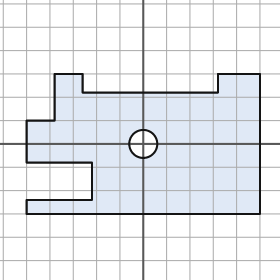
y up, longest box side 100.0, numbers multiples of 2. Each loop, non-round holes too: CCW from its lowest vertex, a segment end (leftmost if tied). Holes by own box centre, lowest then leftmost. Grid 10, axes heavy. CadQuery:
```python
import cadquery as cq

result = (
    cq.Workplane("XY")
    .moveTo(-50.0, -30.0)
    .lineTo(50.0, -30.0)
    .lineTo(50.0, 30.0)
    .lineTo(32.0, 30.0)
    .lineTo(32.0, 22.0)
    .lineTo(-26.0, 22.0)
    .lineTo(-26.0, 30.0)
    .lineTo(-38.0, 30.0)
    .lineTo(-38.0, 10.0)
    .lineTo(-50.0, 10.0)
    .lineTo(-50.0, -8.0)
    .lineTo(-22.0, -8.0)
    .lineTo(-22.0, -24.0)
    .lineTo(-50.0, -24.0)
    .close()
    .moveTo(0.0, 0.0)
    .circle(6.0)
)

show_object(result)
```